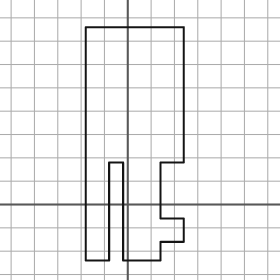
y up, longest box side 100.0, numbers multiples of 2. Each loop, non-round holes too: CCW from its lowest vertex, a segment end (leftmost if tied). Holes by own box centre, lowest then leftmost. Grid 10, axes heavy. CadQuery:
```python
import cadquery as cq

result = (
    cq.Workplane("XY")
    .moveTo(-18.0, -24.0)
    .lineTo(-8.0, -24.0)
    .lineTo(-8.0, 18.0)
    .lineTo(-2.0, 18.0)
    .lineTo(-2.0, -24.0)
    .lineTo(14.0, -24.0)
    .lineTo(14.0, -16.0)
    .lineTo(24.0, -16.0)
    .lineTo(24.0, -6.0)
    .lineTo(14.0, -6.0)
    .lineTo(14.0, 18.0)
    .lineTo(24.0, 18.0)
    .lineTo(24.0, 76.0)
    .lineTo(-18.0, 76.0)
    .close()
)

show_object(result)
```